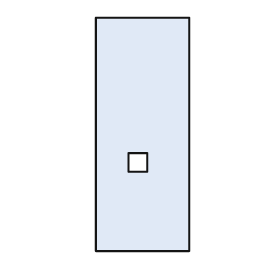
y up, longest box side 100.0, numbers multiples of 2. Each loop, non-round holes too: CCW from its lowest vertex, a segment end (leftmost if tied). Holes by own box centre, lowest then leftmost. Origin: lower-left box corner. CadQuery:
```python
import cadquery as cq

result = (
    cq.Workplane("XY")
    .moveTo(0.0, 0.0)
    .lineTo(40.0, 0.0)
    .lineTo(40.0, 100.0)
    .lineTo(0.0, 100.0)
    .close()
    .moveTo(14.0, 34.0)
    .lineTo(22.0, 34.0)
    .lineTo(22.0, 42.0)
    .lineTo(14.0, 42.0)
    .close()
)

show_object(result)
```